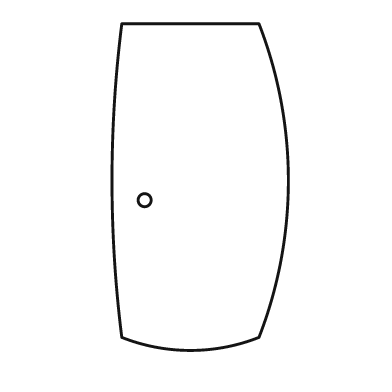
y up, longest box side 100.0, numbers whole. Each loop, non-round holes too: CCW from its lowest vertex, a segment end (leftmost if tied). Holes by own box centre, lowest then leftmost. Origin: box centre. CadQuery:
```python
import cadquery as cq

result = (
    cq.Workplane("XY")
    .moveTo(-24.0, -46.0)
    .threePointArc((-3.0, -50.0), (18.0, -46.0))
    .threePointArc((27.0, 2.0), (18.0, 50.0))
    .lineTo(-24.0, 50.0)
    .threePointArc((-27.0, 2.0), (-24.0, -46.0))
    .close()
    .moveTo(-17.0, -4.0)
    .circle(2.0)
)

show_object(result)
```